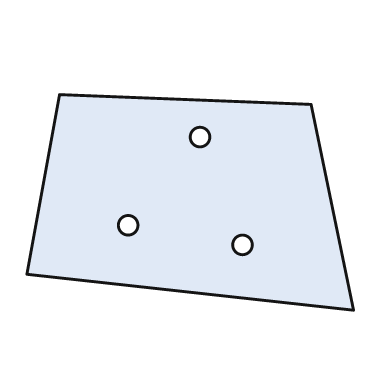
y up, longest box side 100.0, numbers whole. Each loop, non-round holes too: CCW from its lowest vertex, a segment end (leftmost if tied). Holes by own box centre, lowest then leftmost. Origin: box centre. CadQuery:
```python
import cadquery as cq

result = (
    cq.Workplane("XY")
    .moveTo(50.0, -33.0)
    .lineTo(37.0, 30.0)
    .lineTo(-40.0, 33.0)
    .lineTo(-50.0, -22.0)
    .close()
    .moveTo(16.0, -13.0)
    .circle(3.0)
    .moveTo(-19.0, -7.0)
    .circle(3.0)
    .moveTo(3.0, 20.0)
    .circle(3.0)
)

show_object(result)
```